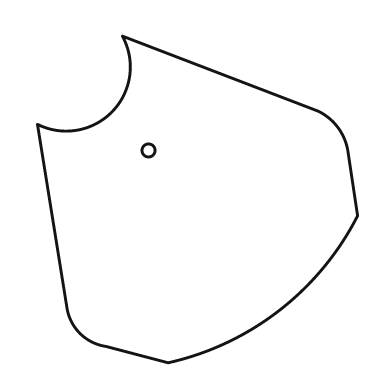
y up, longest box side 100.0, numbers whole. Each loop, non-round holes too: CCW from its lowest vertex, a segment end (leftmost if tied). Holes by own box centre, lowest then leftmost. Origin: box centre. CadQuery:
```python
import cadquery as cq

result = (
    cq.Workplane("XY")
    .moveTo(-9.0, -50.0)
    .threePointArc((25.0, -34.0), (49.0, -5.0))
    .lineTo(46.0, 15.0)
    .threePointArc((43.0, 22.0), (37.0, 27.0))
    .lineTo(-23.0, 50.0)
    .threePointArc((-26.0, 27.0), (-49.0, 23.0))
    .lineTo(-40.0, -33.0)
    .threePointArc((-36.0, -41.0), (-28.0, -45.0))
    .close()
    .moveTo(-15.0, 15.0)
    .circle(2.0)
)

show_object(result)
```